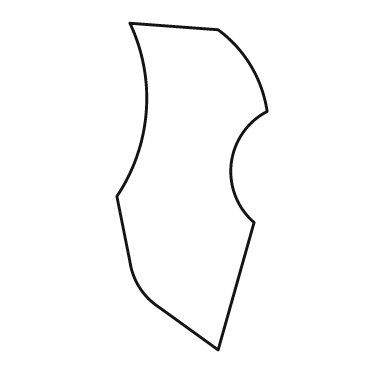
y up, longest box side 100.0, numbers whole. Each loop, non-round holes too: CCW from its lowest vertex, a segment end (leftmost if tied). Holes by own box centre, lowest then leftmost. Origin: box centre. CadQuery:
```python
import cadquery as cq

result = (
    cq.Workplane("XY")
    .moveTo(8.0, -50.0)
    .lineTo(19.0, -11.0)
    .threePointArc((12.0, 7.0), (23.0, 23.0))
    .threePointArc((18.0, 37.0), (8.0, 48.0))
    .lineTo(-19.0, 50.0)
    .threePointArc((-14.0, 23.0), (-23.0, -3.0))
    .lineTo(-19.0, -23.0)
    .threePointArc((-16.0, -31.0), (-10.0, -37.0))
    .close()
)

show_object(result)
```